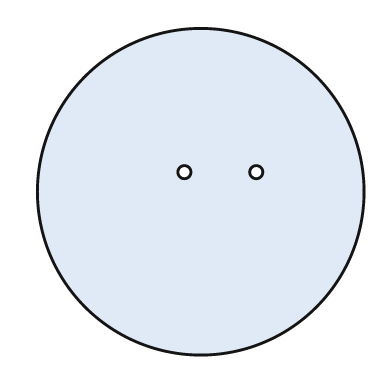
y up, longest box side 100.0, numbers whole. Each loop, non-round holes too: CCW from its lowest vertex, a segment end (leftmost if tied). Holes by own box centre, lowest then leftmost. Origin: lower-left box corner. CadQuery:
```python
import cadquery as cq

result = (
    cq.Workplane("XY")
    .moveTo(50.0, 50.0)
    .circle(50.0)
    .moveTo(45.0, 56.0)
    .circle(2.0)
    .moveTo(67.0, 56.0)
    .circle(2.0)
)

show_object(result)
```